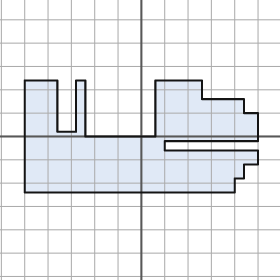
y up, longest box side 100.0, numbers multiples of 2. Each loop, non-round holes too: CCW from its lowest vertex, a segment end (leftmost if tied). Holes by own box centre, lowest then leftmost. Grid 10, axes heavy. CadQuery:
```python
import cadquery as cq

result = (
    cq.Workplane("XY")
    .moveTo(-50.0, -24.0)
    .lineTo(40.0, -24.0)
    .lineTo(40.0, -18.0)
    .lineTo(44.0, -18.0)
    .lineTo(44.0, -12.0)
    .lineTo(50.0, -12.0)
    .lineTo(50.0, -6.0)
    .lineTo(10.0, -6.0)
    .lineTo(10.0, -2.0)
    .lineTo(50.0, -2.0)
    .lineTo(50.0, 10.0)
    .lineTo(44.0, 10.0)
    .lineTo(44.0, 16.0)
    .lineTo(26.0, 16.0)
    .lineTo(26.0, 24.0)
    .lineTo(6.0, 24.0)
    .lineTo(6.0, 0.0)
    .lineTo(-24.0, 0.0)
    .lineTo(-24.0, 24.0)
    .lineTo(-28.0, 24.0)
    .lineTo(-28.0, 2.0)
    .lineTo(-36.0, 2.0)
    .lineTo(-36.0, 24.0)
    .lineTo(-50.0, 24.0)
    .close()
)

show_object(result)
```